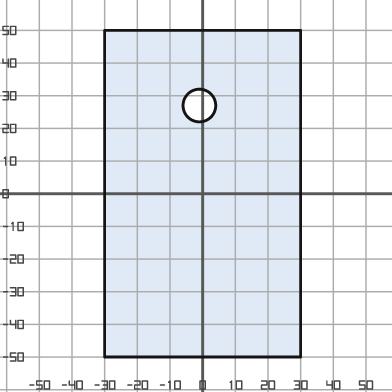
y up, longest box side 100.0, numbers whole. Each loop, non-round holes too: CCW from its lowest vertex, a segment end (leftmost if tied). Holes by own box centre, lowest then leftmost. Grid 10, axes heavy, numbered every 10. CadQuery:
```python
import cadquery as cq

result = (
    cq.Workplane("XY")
    .moveTo(-30.0, -50.0)
    .lineTo(30.0, -50.0)
    .lineTo(30.0, 50.0)
    .lineTo(-30.0, 50.0)
    .close()
    .moveTo(-1.0, 27.0)
    .circle(5.0)
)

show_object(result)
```